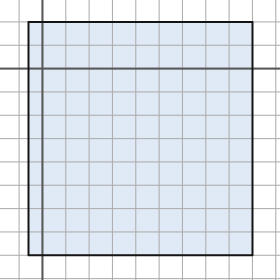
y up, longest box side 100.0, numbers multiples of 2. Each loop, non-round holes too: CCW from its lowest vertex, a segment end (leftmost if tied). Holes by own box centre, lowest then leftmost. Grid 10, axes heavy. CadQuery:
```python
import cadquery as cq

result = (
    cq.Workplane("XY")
    .moveTo(-6.0, -80.0)
    .lineTo(90.0, -80.0)
    .lineTo(90.0, 20.0)
    .lineTo(-6.0, 20.0)
    .close()
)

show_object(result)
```